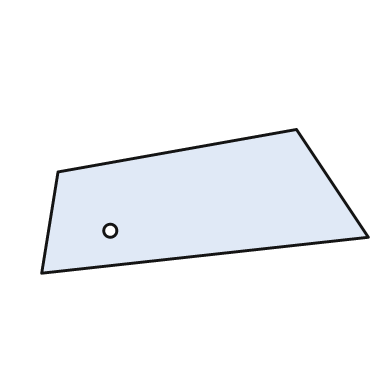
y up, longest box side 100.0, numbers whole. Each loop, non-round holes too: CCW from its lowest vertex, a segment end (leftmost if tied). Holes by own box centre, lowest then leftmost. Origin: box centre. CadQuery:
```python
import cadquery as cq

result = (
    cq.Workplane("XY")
    .moveTo(-50.0, -22.0)
    .lineTo(50.0, -11.0)
    .lineTo(28.0, 22.0)
    .lineTo(-45.0, 9.0)
    .close()
    .moveTo(-29.0, -9.0)
    .circle(2.0)
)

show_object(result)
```